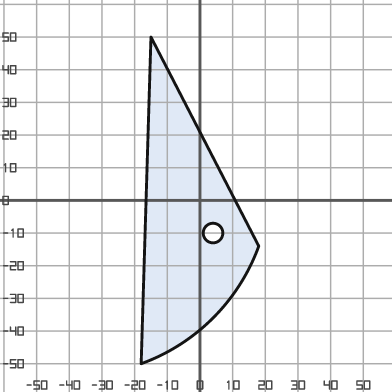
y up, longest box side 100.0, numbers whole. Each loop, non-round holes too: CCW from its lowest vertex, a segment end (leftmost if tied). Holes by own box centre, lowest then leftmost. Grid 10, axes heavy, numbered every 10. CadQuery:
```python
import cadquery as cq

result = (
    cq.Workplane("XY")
    .moveTo(-18.0, -50.0)
    .threePointArc((4.0, -36.0), (18.0, -14.0))
    .lineTo(-15.0, 50.0)
    .close()
    .moveTo(4.0, -10.0)
    .circle(3.0)
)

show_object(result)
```